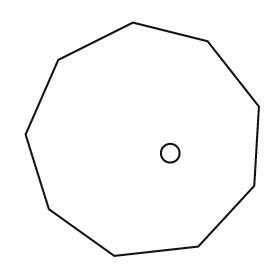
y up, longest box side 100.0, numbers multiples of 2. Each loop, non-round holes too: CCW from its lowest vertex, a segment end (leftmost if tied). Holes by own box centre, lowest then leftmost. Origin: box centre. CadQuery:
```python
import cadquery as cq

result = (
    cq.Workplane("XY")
    .moveTo(-12.0, -50.0)
    .lineTo(24.0, -46.0)
    .lineTo(48.0, -20.0)
    .lineTo(50.0, 14.0)
    .lineTo(28.0, 42.0)
    .lineTo(-4.0, 50.0)
    .lineTo(-36.0, 34.0)
    .lineTo(-50.0, 2.0)
    .lineTo(-40.0, -30.0)
    .close()
    .moveTo(12.0, -6.0)
    .circle(4.0)
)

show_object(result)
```